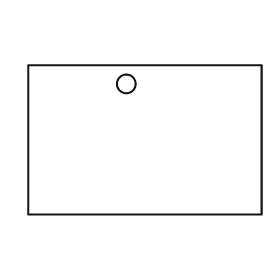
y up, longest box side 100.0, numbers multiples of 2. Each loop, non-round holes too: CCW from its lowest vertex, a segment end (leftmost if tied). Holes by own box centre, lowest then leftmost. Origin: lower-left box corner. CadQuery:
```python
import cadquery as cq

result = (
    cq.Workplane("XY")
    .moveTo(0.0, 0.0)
    .lineTo(100.0, 0.0)
    .lineTo(100.0, 64.0)
    .lineTo(0.0, 64.0)
    .close()
    .moveTo(42.0, 56.0)
    .circle(4.0)
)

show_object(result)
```